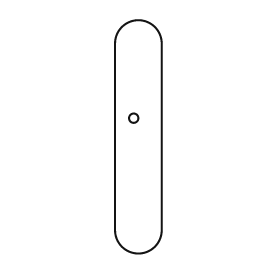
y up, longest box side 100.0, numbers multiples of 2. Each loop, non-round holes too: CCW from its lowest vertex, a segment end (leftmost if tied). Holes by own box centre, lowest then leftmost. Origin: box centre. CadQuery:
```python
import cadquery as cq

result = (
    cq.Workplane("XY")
    .moveTo(-10.0, -40.0)
    .threePointArc((0.0, -50.0), (10.0, -40.0))
    .lineTo(10.0, 40.0)
    .threePointArc((0.0, 50.0), (-10.0, 40.0))
    .close()
    .moveTo(-2.0, 8.0)
    .circle(2.0)
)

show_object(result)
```